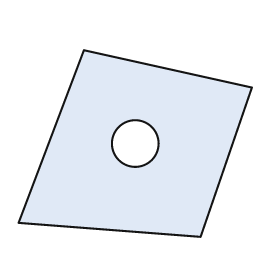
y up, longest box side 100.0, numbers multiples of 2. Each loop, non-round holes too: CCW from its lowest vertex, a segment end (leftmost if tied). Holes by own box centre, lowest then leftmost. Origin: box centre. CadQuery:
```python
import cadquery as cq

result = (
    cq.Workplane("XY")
    .moveTo(28.0, -40.0)
    .lineTo(50.0, 24.0)
    .lineTo(-22.0, 40.0)
    .lineTo(-50.0, -34.0)
    .close()
    .moveTo(0.0, 0.0)
    .circle(10.0)
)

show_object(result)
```